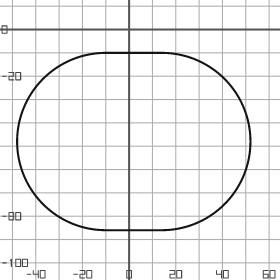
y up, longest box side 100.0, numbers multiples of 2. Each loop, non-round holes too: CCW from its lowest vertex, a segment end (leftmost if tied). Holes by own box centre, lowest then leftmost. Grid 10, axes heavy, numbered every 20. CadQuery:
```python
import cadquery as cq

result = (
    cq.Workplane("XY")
    .moveTo(-10.0, -86.0)
    .lineTo(14.0, -86.0)
    .threePointArc((52.0, -48.0), (14.0, -10.0))
    .lineTo(-10.0, -10.0)
    .threePointArc((-48.0, -48.0), (-10.0, -86.0))
    .close()
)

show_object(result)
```